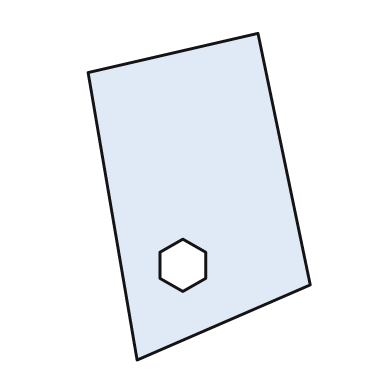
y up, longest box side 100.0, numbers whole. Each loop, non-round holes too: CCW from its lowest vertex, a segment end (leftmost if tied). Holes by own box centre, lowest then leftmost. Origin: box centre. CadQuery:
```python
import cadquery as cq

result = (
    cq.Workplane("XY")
    .moveTo(-19.0, -50.0)
    .lineTo(34.0, -27.0)
    .lineTo(18.0, 50.0)
    .lineTo(-34.0, 38.0)
    .close()
    .moveTo(-5.0, -29.0)
    .lineTo(2.0, -25.0)
    .lineTo(2.0, -17.0)
    .lineTo(-5.0, -13.0)
    .lineTo(-12.0, -17.0)
    .lineTo(-12.0, -25.0)
    .close()
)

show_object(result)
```